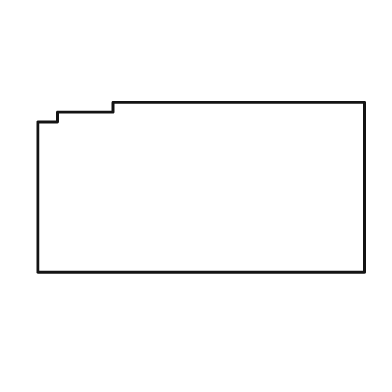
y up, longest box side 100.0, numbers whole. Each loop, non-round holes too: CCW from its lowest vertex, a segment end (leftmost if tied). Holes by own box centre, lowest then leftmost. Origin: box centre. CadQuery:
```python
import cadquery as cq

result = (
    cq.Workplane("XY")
    .moveTo(-50.0, -26.0)
    .lineTo(50.0, -26.0)
    .lineTo(50.0, 26.0)
    .lineTo(-27.0, 26.0)
    .lineTo(-27.0, 23.0)
    .lineTo(-44.0, 23.0)
    .lineTo(-44.0, 20.0)
    .lineTo(-50.0, 20.0)
    .close()
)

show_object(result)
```